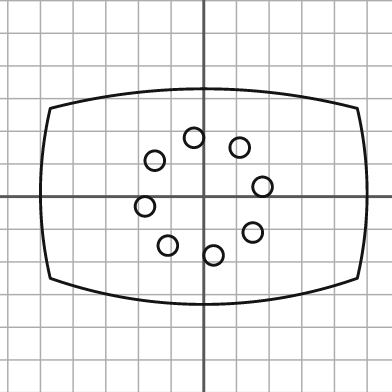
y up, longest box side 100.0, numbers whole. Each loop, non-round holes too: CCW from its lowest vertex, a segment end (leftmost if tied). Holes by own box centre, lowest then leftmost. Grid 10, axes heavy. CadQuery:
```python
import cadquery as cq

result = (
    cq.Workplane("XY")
    .moveTo(-47.0, -25.0)
    .threePointArc((0.0, -33.0), (47.0, -25.0))
    .threePointArc((50.0, 1.0), (47.0, 27.0))
    .threePointArc((0.0, 33.0), (-47.0, 27.0))
    .threePointArc((-50.0, 1.0), (-47.0, -25.0))
    .close()
    .moveTo(3.0, -18.0)
    .circle(3.0)
    .moveTo(-11.0, -15.0)
    .circle(3.0)
    .moveTo(15.0, -11.0)
    .circle(3.0)
    .moveTo(-18.0, -3.0)
    .circle(3.0)
    .moveTo(18.0, 3.0)
    .circle(3.0)
    .moveTo(-15.0, 11.0)
    .circle(3.0)
    .moveTo(11.0, 15.0)
    .circle(3.0)
    .moveTo(-3.0, 18.0)
    .circle(3.0)
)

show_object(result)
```